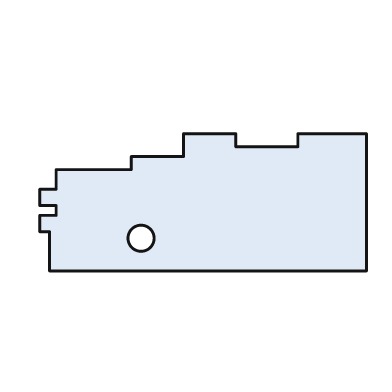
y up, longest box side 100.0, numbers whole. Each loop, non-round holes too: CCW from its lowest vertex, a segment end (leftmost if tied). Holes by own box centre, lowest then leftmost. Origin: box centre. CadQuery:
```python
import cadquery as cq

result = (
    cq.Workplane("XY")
    .moveTo(-47.0, -21.0)
    .lineTo(50.0, -21.0)
    .lineTo(50.0, 21.0)
    .lineTo(29.0, 21.0)
    .lineTo(29.0, 17.0)
    .lineTo(10.0, 17.0)
    .lineTo(10.0, 21.0)
    .lineTo(-6.0, 21.0)
    .lineTo(-6.0, 14.0)
    .lineTo(-22.0, 14.0)
    .lineTo(-22.0, 10.0)
    .lineTo(-45.0, 10.0)
    .lineTo(-45.0, 4.0)
    .lineTo(-50.0, 4.0)
    .lineTo(-50.0, -1.0)
    .lineTo(-45.0, -1.0)
    .lineTo(-45.0, -4.0)
    .lineTo(-50.0, -4.0)
    .lineTo(-50.0, -9.0)
    .lineTo(-47.0, -9.0)
    .close()
    .moveTo(-19.0, -11.0)
    .circle(4.0)
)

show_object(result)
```